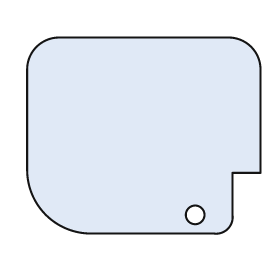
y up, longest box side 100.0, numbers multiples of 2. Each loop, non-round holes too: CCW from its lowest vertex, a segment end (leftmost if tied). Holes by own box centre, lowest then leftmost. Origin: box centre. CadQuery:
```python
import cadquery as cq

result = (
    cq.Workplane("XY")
    .moveTo(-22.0, -42.0)
    .lineTo(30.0, -42.0)
    .threePointArc((36.0, -40.0), (38.0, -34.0))
    .lineTo(38.0, -16.0)
    .lineTo(50.0, -16.0)
    .lineTo(50.0, 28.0)
    .threePointArc((46.0, 38.0), (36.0, 42.0))
    .lineTo(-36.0, 42.0)
    .threePointArc((-46.0, 38.0), (-50.0, 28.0))
    .lineTo(-50.0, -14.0)
    .threePointArc((-42.0, -34.0), (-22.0, -42.0))
    .close()
    .moveTo(22.0, -34.0)
    .circle(4.0)
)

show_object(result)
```